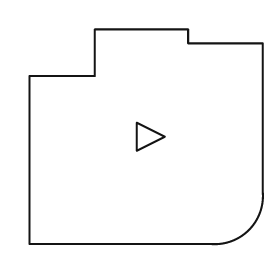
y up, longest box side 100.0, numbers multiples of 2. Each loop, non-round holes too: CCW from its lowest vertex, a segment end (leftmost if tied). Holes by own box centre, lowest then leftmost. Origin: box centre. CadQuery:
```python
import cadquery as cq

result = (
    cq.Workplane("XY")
    .moveTo(-50.0, -46.0)
    .lineTo(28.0, -46.0)
    .threePointArc((44.0, -40.0), (50.0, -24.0))
    .lineTo(50.0, 40.0)
    .lineTo(18.0, 40.0)
    .lineTo(18.0, 46.0)
    .lineTo(-22.0, 46.0)
    .lineTo(-22.0, 26.0)
    .lineTo(-50.0, 26.0)
    .close()
    .moveTo(-4.0, -6.0)
    .lineTo(8.0, 0.0)
    .lineTo(-4.0, 6.0)
    .close()
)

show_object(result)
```